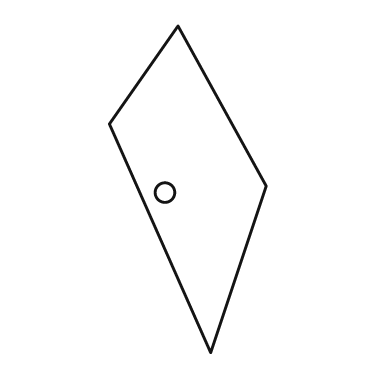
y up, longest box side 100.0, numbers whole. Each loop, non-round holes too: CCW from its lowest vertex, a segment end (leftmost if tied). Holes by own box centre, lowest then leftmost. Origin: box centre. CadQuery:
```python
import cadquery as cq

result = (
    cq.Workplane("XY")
    .moveTo(7.0, -50.0)
    .lineTo(24.0, 1.0)
    .lineTo(-3.0, 50.0)
    .lineTo(-24.0, 20.0)
    .close()
    .moveTo(-7.0, -1.0)
    .circle(3.0)
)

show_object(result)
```